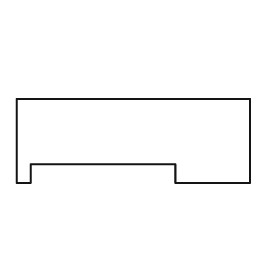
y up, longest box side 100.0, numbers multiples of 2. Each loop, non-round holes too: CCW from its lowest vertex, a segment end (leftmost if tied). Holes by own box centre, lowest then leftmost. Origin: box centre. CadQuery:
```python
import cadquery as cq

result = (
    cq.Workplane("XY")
    .moveTo(-50.0, -18.0)
    .lineTo(-44.0, -18.0)
    .lineTo(-44.0, -10.0)
    .lineTo(18.0, -10.0)
    .lineTo(18.0, -18.0)
    .lineTo(50.0, -18.0)
    .lineTo(50.0, 18.0)
    .lineTo(-50.0, 18.0)
    .close()
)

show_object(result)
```